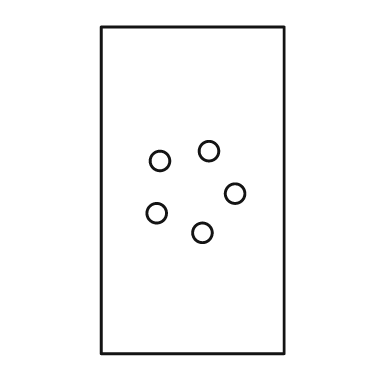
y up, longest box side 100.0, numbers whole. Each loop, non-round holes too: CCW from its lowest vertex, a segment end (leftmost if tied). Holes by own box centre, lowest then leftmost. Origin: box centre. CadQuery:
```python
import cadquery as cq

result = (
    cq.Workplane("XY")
    .moveTo(-28.0, -50.0)
    .lineTo(28.0, -50.0)
    .lineTo(28.0, 50.0)
    .lineTo(-28.0, 50.0)
    .close()
    .moveTo(3.0, -13.0)
    .circle(3.0)
    .moveTo(-11.0, -7.0)
    .circle(3.0)
    .moveTo(13.0, -1.0)
    .circle(3.0)
    .moveTo(-10.0, 9.0)
    .circle(3.0)
    .moveTo(5.0, 12.0)
    .circle(3.0)
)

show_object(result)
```